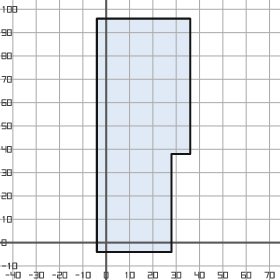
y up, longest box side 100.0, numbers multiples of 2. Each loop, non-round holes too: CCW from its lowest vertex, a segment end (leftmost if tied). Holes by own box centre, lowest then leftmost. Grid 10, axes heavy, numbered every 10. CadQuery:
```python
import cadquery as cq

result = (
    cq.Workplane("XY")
    .moveTo(-4.0, -4.0)
    .lineTo(28.0, -4.0)
    .lineTo(28.0, 38.0)
    .lineTo(36.0, 38.0)
    .lineTo(36.0, 96.0)
    .lineTo(-4.0, 96.0)
    .close()
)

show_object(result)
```